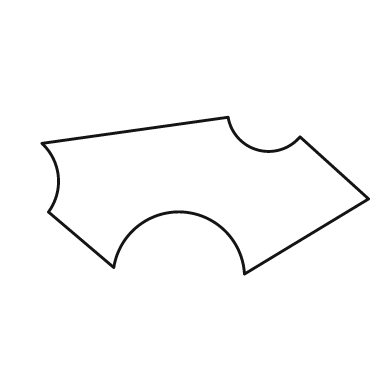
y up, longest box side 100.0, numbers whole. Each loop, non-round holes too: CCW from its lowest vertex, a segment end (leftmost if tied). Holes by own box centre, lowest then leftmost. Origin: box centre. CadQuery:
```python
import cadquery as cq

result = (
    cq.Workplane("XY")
    .moveTo(12.0, -24.0)
    .lineTo(50.0, -1.0)
    .lineTo(29.0, 18.0)
    .threePointArc((16.0, 14.0), (7.0, 24.0))
    .lineTo(-50.0, 16.0)
    .threePointArc((-45.0, 6.0), (-48.0, -5.0))
    .lineTo(-28.0, -22.0)
    .threePointArc((-7.0, -5.0), (12.0, -24.0))
    .close()
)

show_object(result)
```